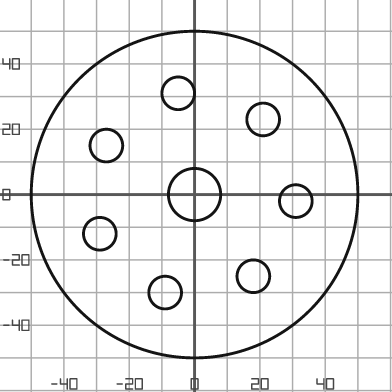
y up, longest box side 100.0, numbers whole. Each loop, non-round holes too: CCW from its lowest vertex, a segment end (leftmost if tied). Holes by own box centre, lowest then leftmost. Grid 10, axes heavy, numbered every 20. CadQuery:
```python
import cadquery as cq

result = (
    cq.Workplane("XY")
    .moveTo(0.0, 0.0)
    .circle(50.0)
    .moveTo(-9.0, -30.0)
    .circle(5.0)
    .moveTo(18.0, -25.0)
    .circle(5.0)
    .moveTo(-29.0, -12.0)
    .circle(5.0)
    .moveTo(31.0, -2.0)
    .circle(5.0)
    .moveTo(0.0, 0.0)
    .circle(8.0)
    .moveTo(-27.0, 15.0)
    .circle(5.0)
    .moveTo(21.0, 23.0)
    .circle(5.0)
    .moveTo(-5.0, 31.0)
    .circle(5.0)
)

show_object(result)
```